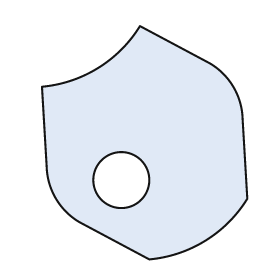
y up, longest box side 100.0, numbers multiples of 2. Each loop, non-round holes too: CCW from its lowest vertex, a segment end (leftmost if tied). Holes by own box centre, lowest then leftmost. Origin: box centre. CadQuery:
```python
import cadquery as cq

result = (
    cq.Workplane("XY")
    .moveTo(2.0, -50.0)
    .threePointArc((26.0, -42.0), (44.0, -24.0))
    .lineTo(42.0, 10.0)
    .threePointArc((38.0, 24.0), (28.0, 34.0))
    .lineTo(-2.0, 50.0)
    .threePointArc((-20.0, 32.0), (-44.0, 24.0))
    .lineTo(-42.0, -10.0)
    .threePointArc((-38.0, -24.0), (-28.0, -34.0))
    .close()
    .moveTo(-10.0, -16.0)
    .circle(12.0)
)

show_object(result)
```